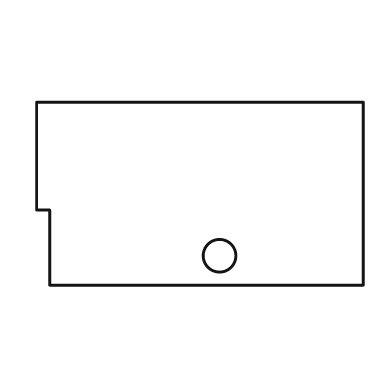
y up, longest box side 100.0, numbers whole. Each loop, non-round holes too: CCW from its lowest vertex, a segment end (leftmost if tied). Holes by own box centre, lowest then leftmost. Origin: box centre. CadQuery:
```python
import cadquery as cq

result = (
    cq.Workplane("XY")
    .moveTo(-46.0, -28.0)
    .lineTo(50.0, -28.0)
    .lineTo(50.0, 28.0)
    .lineTo(-50.0, 28.0)
    .lineTo(-50.0, -5.0)
    .lineTo(-46.0, -5.0)
    .close()
    .moveTo(6.0, -19.0)
    .circle(5.0)
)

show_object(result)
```